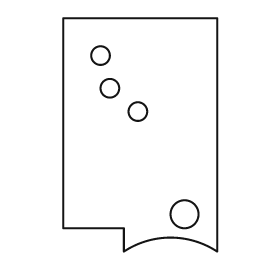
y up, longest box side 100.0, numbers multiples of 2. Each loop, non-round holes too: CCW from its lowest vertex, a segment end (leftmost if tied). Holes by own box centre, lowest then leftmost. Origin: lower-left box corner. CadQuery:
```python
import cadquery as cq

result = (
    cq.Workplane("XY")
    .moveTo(26.0, 0.0)
    .threePointArc((46.0, 6.0), (66.0, 0.0))
    .lineTo(66.0, 100.0)
    .lineTo(0.0, 100.0)
    .lineTo(0.0, 10.0)
    .lineTo(26.0, 10.0)
    .close()
    .moveTo(52.0, 16.0)
    .circle(6.0)
    .moveTo(32.0, 60.0)
    .circle(4.0)
    .moveTo(20.0, 70.0)
    .circle(4.0)
    .moveTo(16.0, 84.0)
    .circle(4.0)
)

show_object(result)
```